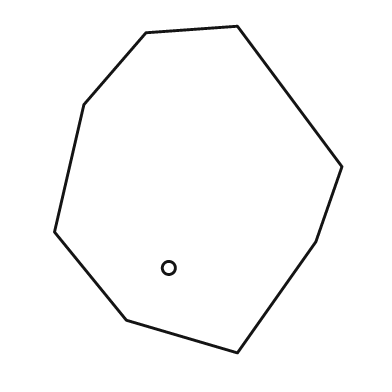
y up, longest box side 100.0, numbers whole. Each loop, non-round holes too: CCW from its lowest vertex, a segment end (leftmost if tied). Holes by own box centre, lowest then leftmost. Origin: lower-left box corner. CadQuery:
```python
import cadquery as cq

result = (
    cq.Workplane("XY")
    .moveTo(56.0, 0.0)
    .lineTo(80.0, 34.0)
    .lineTo(88.0, 57.0)
    .lineTo(56.0, 100.0)
    .lineTo(28.0, 98.0)
    .lineTo(9.0, 76.0)
    .lineTo(0.0, 37.0)
    .lineTo(22.0, 10.0)
    .close()
    .moveTo(35.0, 26.0)
    .circle(2.0)
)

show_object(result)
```